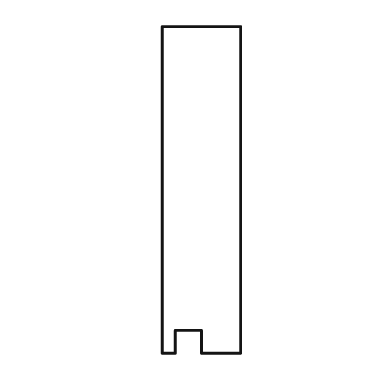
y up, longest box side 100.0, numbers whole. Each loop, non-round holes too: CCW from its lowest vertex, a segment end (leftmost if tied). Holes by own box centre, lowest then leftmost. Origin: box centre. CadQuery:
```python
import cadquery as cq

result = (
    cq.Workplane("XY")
    .moveTo(-12.0, -50.0)
    .lineTo(-8.0, -50.0)
    .lineTo(-8.0, -43.0)
    .lineTo(0.0, -43.0)
    .lineTo(0.0, -50.0)
    .lineTo(12.0, -50.0)
    .lineTo(12.0, 50.0)
    .lineTo(-12.0, 50.0)
    .close()
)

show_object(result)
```